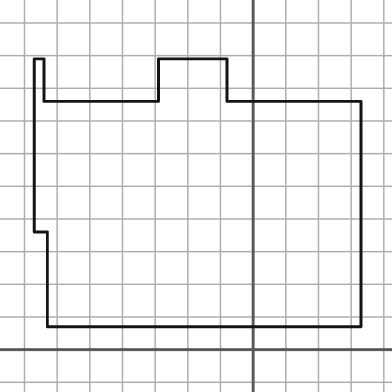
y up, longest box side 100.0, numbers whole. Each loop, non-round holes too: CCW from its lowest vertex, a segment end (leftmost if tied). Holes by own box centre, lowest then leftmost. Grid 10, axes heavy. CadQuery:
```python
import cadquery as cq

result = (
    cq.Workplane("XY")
    .moveTo(-63.0, 7.0)
    .lineTo(33.0, 7.0)
    .lineTo(33.0, 76.0)
    .lineTo(-8.0, 76.0)
    .lineTo(-8.0, 89.0)
    .lineTo(-29.0, 89.0)
    .lineTo(-29.0, 76.0)
    .lineTo(-64.0, 76.0)
    .lineTo(-64.0, 89.0)
    .lineTo(-67.0, 89.0)
    .lineTo(-67.0, 36.0)
    .lineTo(-63.0, 36.0)
    .close()
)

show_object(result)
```